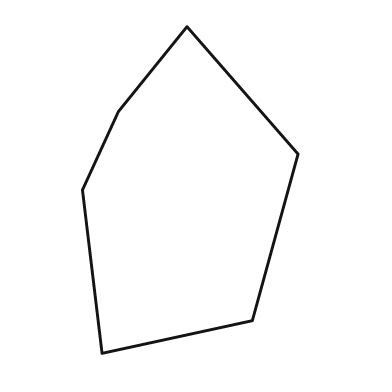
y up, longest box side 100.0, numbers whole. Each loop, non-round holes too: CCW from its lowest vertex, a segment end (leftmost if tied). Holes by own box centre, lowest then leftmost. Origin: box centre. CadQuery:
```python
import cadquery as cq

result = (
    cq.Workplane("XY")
    .moveTo(-27.0, -50.0)
    .lineTo(19.0, -40.0)
    .lineTo(33.0, 11.0)
    .lineTo(-1.0, 50.0)
    .lineTo(-22.0, 24.0)
    .lineTo(-33.0, 0.0)
    .close()
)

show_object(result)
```